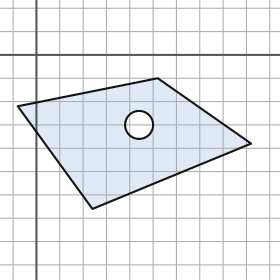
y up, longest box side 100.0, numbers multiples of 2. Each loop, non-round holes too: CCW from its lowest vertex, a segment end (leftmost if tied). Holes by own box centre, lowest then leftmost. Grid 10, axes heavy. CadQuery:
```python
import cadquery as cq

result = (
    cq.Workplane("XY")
    .moveTo(24.0, -66.0)
    .lineTo(92.0, -38.0)
    .lineTo(52.0, -10.0)
    .lineTo(-8.0, -22.0)
    .close()
    .moveTo(44.0, -30.0)
    .circle(6.0)
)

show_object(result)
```